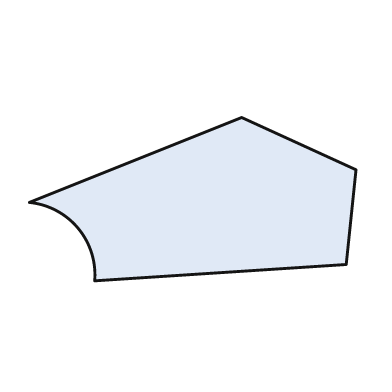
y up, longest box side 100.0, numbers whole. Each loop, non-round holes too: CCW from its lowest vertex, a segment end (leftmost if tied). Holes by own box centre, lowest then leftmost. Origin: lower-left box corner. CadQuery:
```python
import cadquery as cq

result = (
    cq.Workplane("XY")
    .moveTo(20.0, 0.0)
    .lineTo(97.0, 5.0)
    .lineTo(100.0, 34.0)
    .lineTo(65.0, 50.0)
    .lineTo(0.0, 24.0)
    .threePointArc((15.0, 16.0), (20.0, 0.0))
    .close()
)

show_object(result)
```